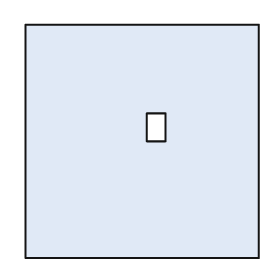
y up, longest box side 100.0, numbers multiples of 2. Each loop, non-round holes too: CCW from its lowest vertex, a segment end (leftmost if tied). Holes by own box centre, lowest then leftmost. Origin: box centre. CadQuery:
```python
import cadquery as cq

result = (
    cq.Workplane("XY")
    .moveTo(-50.0, -50.0)
    .lineTo(50.0, -50.0)
    .lineTo(50.0, 50.0)
    .lineTo(-50.0, 50.0)
    .close()
    .moveTo(2.0, 0.0)
    .lineTo(10.0, 0.0)
    .lineTo(10.0, 12.0)
    .lineTo(2.0, 12.0)
    .close()
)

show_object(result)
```